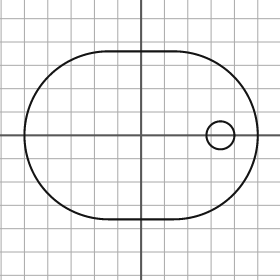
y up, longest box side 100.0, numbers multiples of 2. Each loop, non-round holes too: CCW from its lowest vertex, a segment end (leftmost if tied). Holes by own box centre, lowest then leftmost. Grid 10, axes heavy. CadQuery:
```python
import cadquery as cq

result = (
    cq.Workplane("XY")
    .moveTo(-14.0, -36.0)
    .lineTo(14.0, -36.0)
    .threePointArc((50.0, 0.0), (14.0, 36.0))
    .lineTo(-14.0, 36.0)
    .threePointArc((-50.0, 0.0), (-14.0, -36.0))
    .close()
    .moveTo(34.0, 0.0)
    .circle(6.0)
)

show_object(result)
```